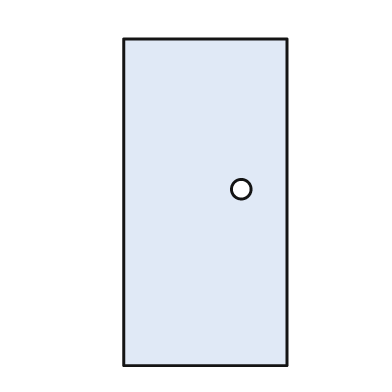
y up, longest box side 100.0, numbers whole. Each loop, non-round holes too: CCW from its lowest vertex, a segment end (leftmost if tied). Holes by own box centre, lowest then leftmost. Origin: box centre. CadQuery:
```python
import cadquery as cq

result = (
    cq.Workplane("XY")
    .moveTo(-25.0, -50.0)
    .lineTo(25.0, -50.0)
    .lineTo(25.0, 50.0)
    .lineTo(-25.0, 50.0)
    .close()
    .moveTo(11.0, 4.0)
    .circle(3.0)
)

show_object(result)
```